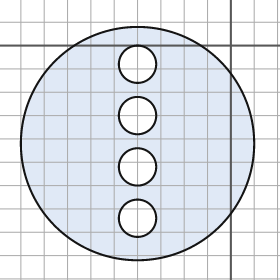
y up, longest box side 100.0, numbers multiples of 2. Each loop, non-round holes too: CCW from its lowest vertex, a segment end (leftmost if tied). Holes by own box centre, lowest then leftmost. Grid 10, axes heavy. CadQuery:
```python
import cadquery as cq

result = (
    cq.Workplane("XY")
    .moveTo(-40.0, -42.0)
    .circle(50.0)
    .moveTo(-40.0, -74.0)
    .circle(8.0)
    .moveTo(-40.0, -52.0)
    .circle(8.0)
    .moveTo(-40.0, -30.0)
    .circle(8.0)
    .moveTo(-40.0, -8.0)
    .circle(8.0)
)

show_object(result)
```